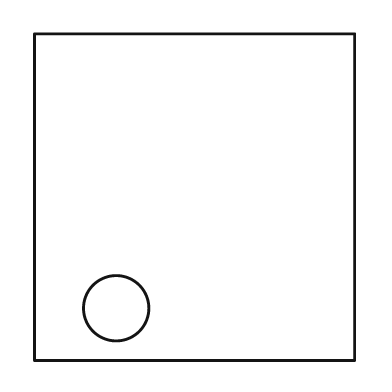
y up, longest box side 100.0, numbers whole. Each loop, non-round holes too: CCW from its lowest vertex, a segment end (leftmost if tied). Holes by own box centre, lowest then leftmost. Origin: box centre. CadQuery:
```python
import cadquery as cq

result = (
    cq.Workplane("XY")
    .moveTo(-49.0, -50.0)
    .lineTo(49.0, -50.0)
    .lineTo(49.0, 50.0)
    .lineTo(-49.0, 50.0)
    .close()
    .moveTo(-24.0, -34.0)
    .circle(10.0)
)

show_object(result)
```